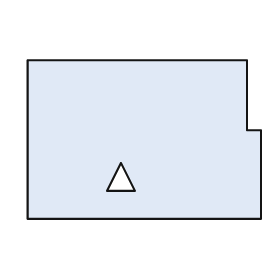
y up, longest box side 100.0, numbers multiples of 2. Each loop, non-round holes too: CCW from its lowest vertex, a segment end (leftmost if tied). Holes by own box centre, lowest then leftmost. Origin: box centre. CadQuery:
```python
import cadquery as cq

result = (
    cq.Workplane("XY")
    .moveTo(-50.0, -34.0)
    .lineTo(50.0, -34.0)
    .lineTo(50.0, 4.0)
    .lineTo(44.0, 4.0)
    .lineTo(44.0, 34.0)
    .lineTo(-50.0, 34.0)
    .close()
    .moveTo(-16.0, -22.0)
    .lineTo(-4.0, -22.0)
    .lineTo(-10.0, -10.0)
    .close()
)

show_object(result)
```